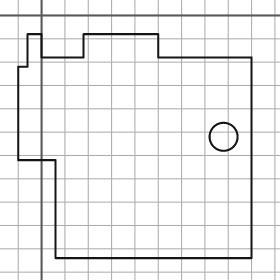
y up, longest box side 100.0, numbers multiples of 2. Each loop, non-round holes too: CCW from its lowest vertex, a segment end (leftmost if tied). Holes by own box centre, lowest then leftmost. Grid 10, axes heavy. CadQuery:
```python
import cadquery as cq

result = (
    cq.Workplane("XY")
    .moveTo(6.0, -104.0)
    .lineTo(90.0, -104.0)
    .lineTo(90.0, -18.0)
    .lineTo(50.0, -18.0)
    .lineTo(50.0, -8.0)
    .lineTo(18.0, -8.0)
    .lineTo(18.0, -18.0)
    .lineTo(0.0, -18.0)
    .lineTo(0.0, -8.0)
    .lineTo(-6.0, -8.0)
    .lineTo(-6.0, -22.0)
    .lineTo(-10.0, -22.0)
    .lineTo(-10.0, -62.0)
    .lineTo(6.0, -62.0)
    .close()
    .moveTo(78.0, -52.0)
    .circle(6.0)
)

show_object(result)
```